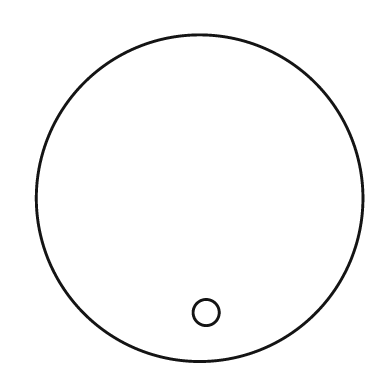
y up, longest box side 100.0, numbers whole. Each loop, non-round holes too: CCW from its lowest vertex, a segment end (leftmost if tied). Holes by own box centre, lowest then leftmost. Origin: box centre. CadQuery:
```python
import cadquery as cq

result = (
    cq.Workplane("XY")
    .moveTo(0.0, 0.0)
    .circle(50.0)
    .moveTo(2.0, -35.0)
    .circle(4.0)
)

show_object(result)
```